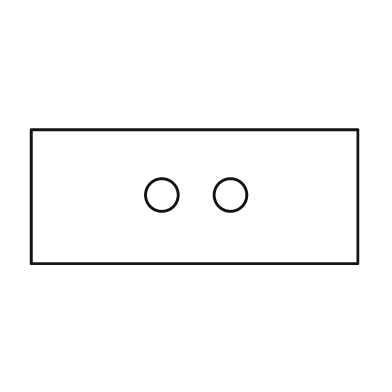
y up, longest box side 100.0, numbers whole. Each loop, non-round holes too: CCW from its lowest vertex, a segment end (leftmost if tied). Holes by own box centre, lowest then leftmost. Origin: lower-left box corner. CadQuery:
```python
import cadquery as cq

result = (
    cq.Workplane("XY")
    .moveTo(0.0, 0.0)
    .lineTo(100.0, 0.0)
    .lineTo(100.0, 41.0)
    .lineTo(0.0, 41.0)
    .close()
    .moveTo(40.0, 21.0)
    .circle(5.0)
    .moveTo(61.0, 21.0)
    .circle(5.0)
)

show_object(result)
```